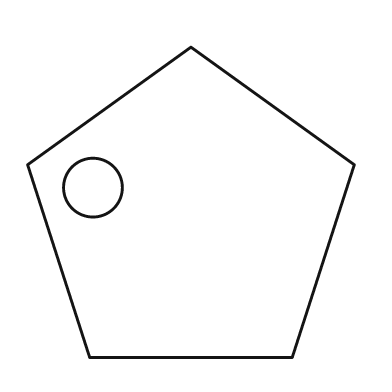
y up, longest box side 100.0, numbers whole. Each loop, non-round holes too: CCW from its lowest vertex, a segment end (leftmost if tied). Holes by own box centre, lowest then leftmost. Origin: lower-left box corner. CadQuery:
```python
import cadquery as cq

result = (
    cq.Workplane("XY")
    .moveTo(19.0, 0.0)
    .lineTo(81.0, 0.0)
    .lineTo(100.0, 59.0)
    .lineTo(50.0, 95.0)
    .lineTo(0.0, 59.0)
    .close()
    .moveTo(20.0, 52.0)
    .circle(9.0)
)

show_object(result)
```